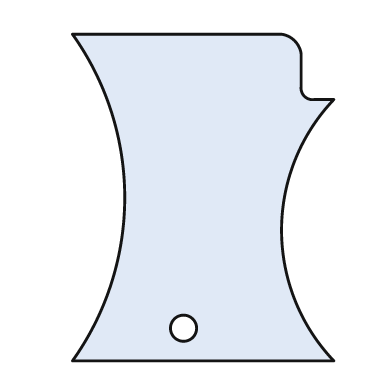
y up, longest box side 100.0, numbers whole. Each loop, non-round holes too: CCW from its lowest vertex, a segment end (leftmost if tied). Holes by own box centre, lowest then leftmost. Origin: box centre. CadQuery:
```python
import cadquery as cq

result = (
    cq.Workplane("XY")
    .moveTo(-40.0, -50.0)
    .lineTo(40.0, -50.0)
    .threePointArc((24.0, -10.0), (40.0, 30.0))
    .lineTo(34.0, 30.0)
    .threePointArc((31.0, 31.0), (30.0, 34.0))
    .lineTo(30.0, 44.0)
    .threePointArc((28.0, 48.0), (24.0, 50.0))
    .lineTo(-40.0, 50.0)
    .threePointArc((-24.0, 0.0), (-40.0, -50.0))
    .close()
    .moveTo(-6.0, -40.0)
    .circle(4.0)
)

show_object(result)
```